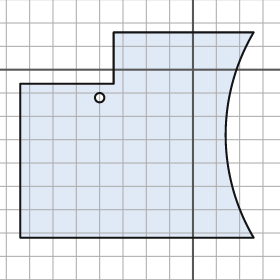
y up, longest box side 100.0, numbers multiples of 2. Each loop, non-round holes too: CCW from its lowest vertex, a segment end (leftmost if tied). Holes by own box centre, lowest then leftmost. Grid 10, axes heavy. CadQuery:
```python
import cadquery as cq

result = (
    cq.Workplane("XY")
    .moveTo(-74.0, -72.0)
    .lineTo(26.0, -72.0)
    .threePointArc((14.0, -28.0), (26.0, 16.0))
    .lineTo(-34.0, 16.0)
    .lineTo(-34.0, -6.0)
    .lineTo(-74.0, -6.0)
    .close()
    .moveTo(-40.0, -12.0)
    .circle(2.0)
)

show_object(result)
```